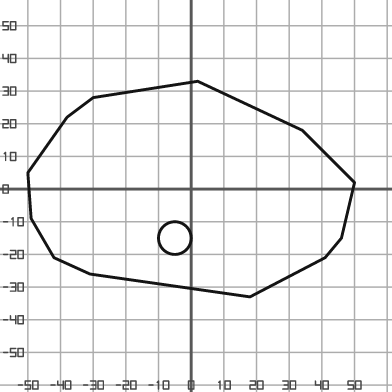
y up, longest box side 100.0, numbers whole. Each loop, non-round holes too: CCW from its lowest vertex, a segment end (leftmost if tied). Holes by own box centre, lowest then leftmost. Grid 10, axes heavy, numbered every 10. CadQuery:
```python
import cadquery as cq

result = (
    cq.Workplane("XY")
    .moveTo(18.0, -33.0)
    .lineTo(41.0, -21.0)
    .lineTo(46.0, -15.0)
    .lineTo(50.0, 2.0)
    .lineTo(34.0, 18.0)
    .lineTo(2.0, 33.0)
    .lineTo(-30.0, 28.0)
    .lineTo(-38.0, 22.0)
    .lineTo(-50.0, 5.0)
    .lineTo(-49.0, -9.0)
    .lineTo(-42.0, -21.0)
    .lineTo(-31.0, -26.0)
    .close()
    .moveTo(-5.0, -15.0)
    .circle(5.0)
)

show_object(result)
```